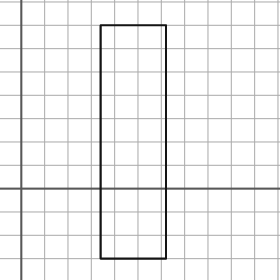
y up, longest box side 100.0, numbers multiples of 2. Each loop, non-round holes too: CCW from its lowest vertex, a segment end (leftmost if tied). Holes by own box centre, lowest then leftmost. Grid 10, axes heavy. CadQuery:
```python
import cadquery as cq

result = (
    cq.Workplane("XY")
    .moveTo(34.0, -30.0)
    .lineTo(62.0, -30.0)
    .lineTo(62.0, 70.0)
    .lineTo(34.0, 70.0)
    .close()
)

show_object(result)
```